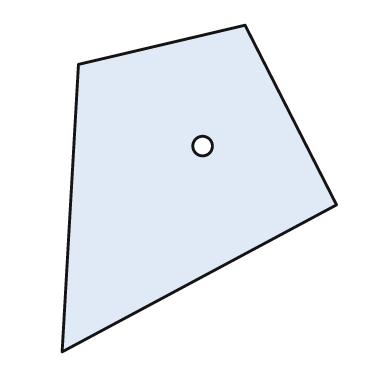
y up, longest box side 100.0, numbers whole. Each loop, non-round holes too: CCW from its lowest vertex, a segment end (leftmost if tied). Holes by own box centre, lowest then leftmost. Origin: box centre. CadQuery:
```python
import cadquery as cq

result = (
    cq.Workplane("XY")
    .moveTo(-42.0, -50.0)
    .lineTo(42.0, -5.0)
    .lineTo(14.0, 50.0)
    .lineTo(-37.0, 38.0)
    .close()
    .moveTo(1.0, 13.0)
    .circle(3.0)
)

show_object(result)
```